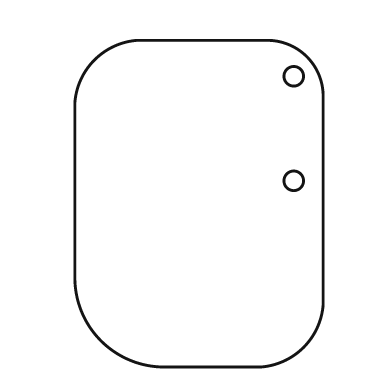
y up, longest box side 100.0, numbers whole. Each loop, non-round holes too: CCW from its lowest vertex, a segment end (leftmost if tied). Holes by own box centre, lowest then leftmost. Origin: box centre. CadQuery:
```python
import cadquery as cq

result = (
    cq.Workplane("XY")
    .moveTo(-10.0, -50.0)
    .lineTo(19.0, -50.0)
    .threePointArc((32.0, -44.0), (38.0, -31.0))
    .lineTo(38.0, 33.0)
    .threePointArc((33.0, 45.0), (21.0, 50.0))
    .lineTo(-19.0, 50.0)
    .threePointArc((-32.0, 44.0), (-38.0, 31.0))
    .lineTo(-38.0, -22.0)
    .threePointArc((-30.0, -42.0), (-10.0, -50.0))
    .close()
    .moveTo(29.0, 7.0)
    .circle(3.0)
    .moveTo(29.0, 39.0)
    .circle(3.0)
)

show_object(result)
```